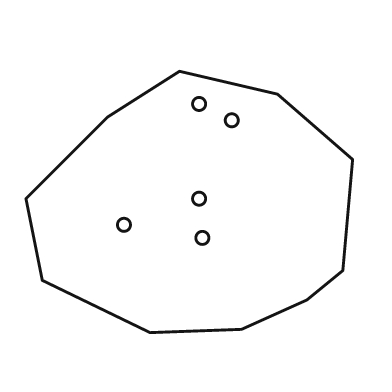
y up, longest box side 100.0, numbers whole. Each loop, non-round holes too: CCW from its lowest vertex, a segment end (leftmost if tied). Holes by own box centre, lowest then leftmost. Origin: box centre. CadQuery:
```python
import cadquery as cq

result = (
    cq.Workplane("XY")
    .moveTo(-12.0, -40.0)
    .lineTo(16.0, -39.0)
    .lineTo(36.0, -30.0)
    .lineTo(47.0, -21.0)
    .lineTo(50.0, 13.0)
    .lineTo(27.0, 33.0)
    .lineTo(-3.0, 40.0)
    .lineTo(-25.0, 26.0)
    .lineTo(-50.0, 1.0)
    .lineTo(-45.0, -24.0)
    .close()
    .moveTo(4.0, -11.0)
    .circle(2.0)
    .moveTo(-20.0, -7.0)
    .circle(2.0)
    .moveTo(3.0, 1.0)
    .circle(2.0)
    .moveTo(13.0, 25.0)
    .circle(2.0)
    .moveTo(3.0, 30.0)
    .circle(2.0)
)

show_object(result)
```